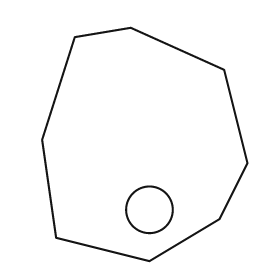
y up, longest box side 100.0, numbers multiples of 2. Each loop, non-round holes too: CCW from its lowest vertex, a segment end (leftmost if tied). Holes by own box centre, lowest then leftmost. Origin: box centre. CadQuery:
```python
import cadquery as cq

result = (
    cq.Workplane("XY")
    .moveTo(2.0, -50.0)
    .lineTo(32.0, -32.0)
    .lineTo(44.0, -8.0)
    .lineTo(34.0, 32.0)
    .lineTo(-6.0, 50.0)
    .lineTo(-30.0, 46.0)
    .lineTo(-44.0, 2.0)
    .lineTo(-38.0, -40.0)
    .close()
    .moveTo(2.0, -28.0)
    .circle(10.0)
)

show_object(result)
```